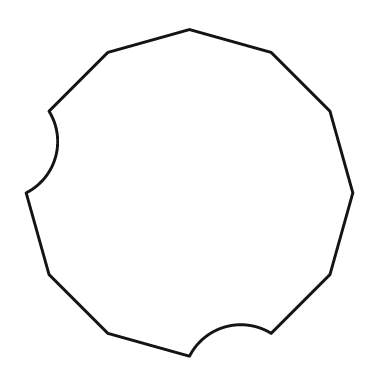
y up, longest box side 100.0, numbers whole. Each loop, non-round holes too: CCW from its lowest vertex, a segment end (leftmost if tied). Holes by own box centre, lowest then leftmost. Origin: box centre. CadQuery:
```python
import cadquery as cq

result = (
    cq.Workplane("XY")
    .moveTo(0.0, -50.0)
    .threePointArc((11.0, -41.0), (25.0, -43.0))
    .lineTo(43.0, -25.0)
    .lineTo(50.0, 0.0)
    .lineTo(43.0, 25.0)
    .lineTo(25.0, 43.0)
    .lineTo(0.0, 50.0)
    .lineTo(-25.0, 43.0)
    .lineTo(-43.0, 25.0)
    .threePointArc((-41.0, 11.0), (-50.0, 0.0))
    .lineTo(-43.0, -25.0)
    .lineTo(-25.0, -43.0)
    .close()
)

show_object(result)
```